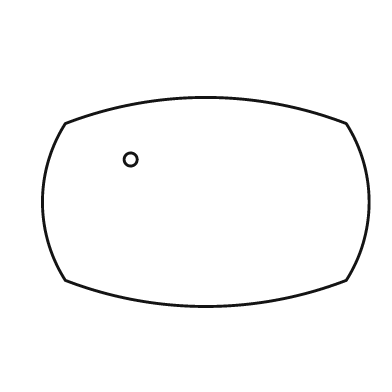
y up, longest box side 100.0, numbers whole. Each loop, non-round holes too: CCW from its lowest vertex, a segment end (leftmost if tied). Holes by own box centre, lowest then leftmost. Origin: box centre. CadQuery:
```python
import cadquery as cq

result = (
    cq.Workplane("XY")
    .moveTo(-43.0, -24.0)
    .threePointArc((0.0, -32.0), (43.0, -24.0))
    .threePointArc((50.0, 0.0), (43.0, 24.0))
    .threePointArc((0.0, 32.0), (-43.0, 24.0))
    .threePointArc((-50.0, 0.0), (-43.0, -24.0))
    .close()
    .moveTo(-23.0, 13.0)
    .circle(2.0)
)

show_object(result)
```